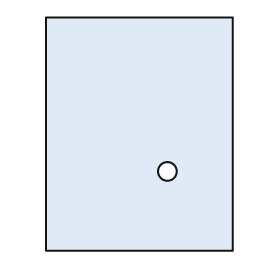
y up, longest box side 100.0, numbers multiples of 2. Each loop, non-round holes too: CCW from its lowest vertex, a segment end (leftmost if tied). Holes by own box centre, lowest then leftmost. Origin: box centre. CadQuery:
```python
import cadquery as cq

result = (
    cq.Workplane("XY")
    .moveTo(-40.0, -50.0)
    .lineTo(40.0, -50.0)
    .lineTo(40.0, 50.0)
    .lineTo(-40.0, 50.0)
    .close()
    .moveTo(12.0, -16.0)
    .circle(4.0)
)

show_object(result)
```